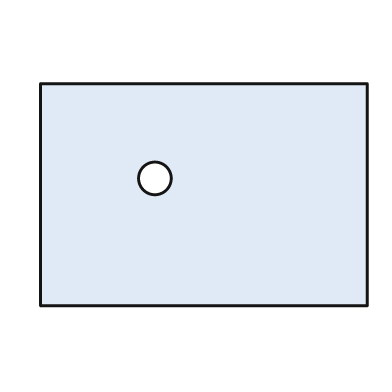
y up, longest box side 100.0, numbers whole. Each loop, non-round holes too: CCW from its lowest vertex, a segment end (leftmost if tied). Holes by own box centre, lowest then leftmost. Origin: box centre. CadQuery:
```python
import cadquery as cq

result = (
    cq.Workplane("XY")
    .moveTo(-50.0, -34.0)
    .lineTo(50.0, -34.0)
    .lineTo(50.0, 34.0)
    .lineTo(-50.0, 34.0)
    .close()
    .moveTo(-15.0, 5.0)
    .circle(5.0)
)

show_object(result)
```